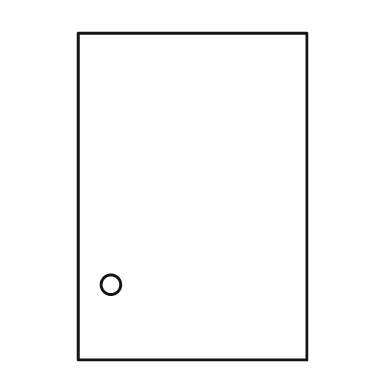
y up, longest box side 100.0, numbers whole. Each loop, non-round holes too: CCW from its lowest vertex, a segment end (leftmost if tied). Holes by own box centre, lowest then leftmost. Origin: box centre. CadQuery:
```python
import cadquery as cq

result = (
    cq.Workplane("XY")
    .moveTo(-35.0, -50.0)
    .lineTo(35.0, -50.0)
    .lineTo(35.0, 50.0)
    .lineTo(-35.0, 50.0)
    .close()
    .moveTo(-25.0, -27.0)
    .circle(3.0)
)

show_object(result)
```